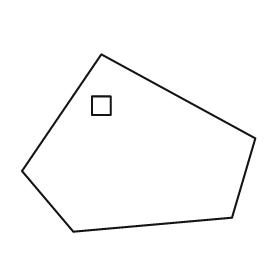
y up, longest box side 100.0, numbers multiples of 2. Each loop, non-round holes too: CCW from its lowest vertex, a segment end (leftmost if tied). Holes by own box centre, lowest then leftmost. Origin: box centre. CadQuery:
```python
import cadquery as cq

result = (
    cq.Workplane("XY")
    .moveTo(-28.0, -38.0)
    .lineTo(40.0, -32.0)
    .lineTo(50.0, 2.0)
    .lineTo(-16.0, 38.0)
    .lineTo(-50.0, -12.0)
    .close()
    .moveTo(-20.0, 12.0)
    .lineTo(-12.0, 12.0)
    .lineTo(-12.0, 20.0)
    .lineTo(-20.0, 20.0)
    .close()
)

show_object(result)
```